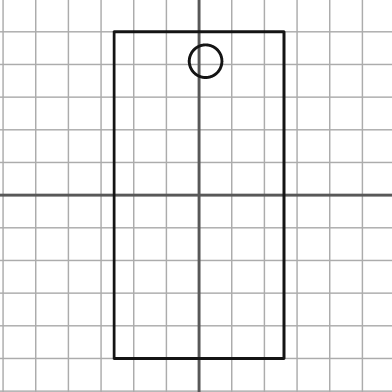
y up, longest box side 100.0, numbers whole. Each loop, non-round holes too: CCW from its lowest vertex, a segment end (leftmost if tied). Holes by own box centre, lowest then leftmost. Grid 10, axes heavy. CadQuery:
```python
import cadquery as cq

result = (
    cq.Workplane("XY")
    .moveTo(-26.0, -50.0)
    .lineTo(26.0, -50.0)
    .lineTo(26.0, 50.0)
    .lineTo(-26.0, 50.0)
    .close()
    .moveTo(2.0, 41.0)
    .circle(5.0)
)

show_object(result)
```